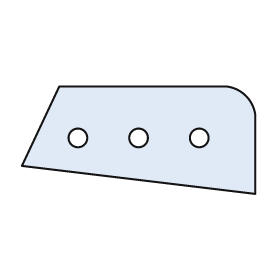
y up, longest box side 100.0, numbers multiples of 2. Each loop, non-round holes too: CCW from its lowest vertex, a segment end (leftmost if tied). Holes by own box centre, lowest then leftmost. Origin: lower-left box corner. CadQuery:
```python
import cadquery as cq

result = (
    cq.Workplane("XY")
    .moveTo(100.0, 0.0)
    .lineTo(100.0, 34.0)
    .threePointArc((96.0, 42.0), (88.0, 46.0))
    .lineTo(16.0, 46.0)
    .lineTo(0.0, 12.0)
    .close()
    .moveTo(24.0, 24.0)
    .circle(4.0)
    .moveTo(50.0, 24.0)
    .circle(4.0)
    .moveTo(76.0, 24.0)
    .circle(4.0)
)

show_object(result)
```